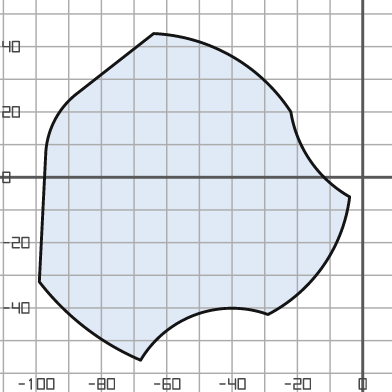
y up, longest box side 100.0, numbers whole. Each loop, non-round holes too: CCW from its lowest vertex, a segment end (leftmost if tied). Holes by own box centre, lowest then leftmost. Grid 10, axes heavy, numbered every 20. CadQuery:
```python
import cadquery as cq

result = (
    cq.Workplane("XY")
    .moveTo(-68.0, -56.0)
    .threePointArc((-51.0, -42.0), (-29.0, -42.0))
    .threePointArc((-12.0, -27.0), (-4.0, -6.0))
    .threePointArc((-16.0, 5.0), (-22.0, 20.0))
    .threePointArc((-40.0, 37.0), (-64.0, 44.0))
    .lineTo(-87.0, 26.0)
    .threePointArc((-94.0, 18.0), (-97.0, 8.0))
    .lineTo(-99.0, -32.0)
    .threePointArc((-85.0, -46.0), (-68.0, -56.0))
    .close()
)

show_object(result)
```